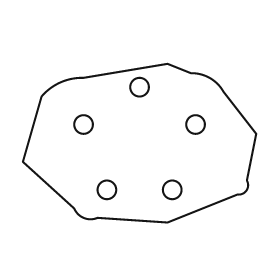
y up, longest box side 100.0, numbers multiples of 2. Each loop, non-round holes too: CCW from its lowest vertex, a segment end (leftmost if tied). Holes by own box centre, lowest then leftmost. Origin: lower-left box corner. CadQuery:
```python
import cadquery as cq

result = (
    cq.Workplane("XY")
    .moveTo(62.0, 0.0)
    .lineTo(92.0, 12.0)
    .threePointArc((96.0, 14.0), (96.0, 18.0))
    .lineTo(100.0, 38.0)
    .lineTo(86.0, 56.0)
    .threePointArc((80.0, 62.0), (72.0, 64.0))
    .lineTo(62.0, 68.0)
    .lineTo(26.0, 62.0)
    .threePointArc((16.0, 60.0), (8.0, 54.0))
    .lineTo(0.0, 26.0)
    .lineTo(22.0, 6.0)
    .threePointArc((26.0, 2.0), (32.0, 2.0))
    .close()
    .moveTo(36.0, 14.0)
    .circle(4.0)
    .moveTo(64.0, 14.0)
    .circle(4.0)
    .moveTo(26.0, 42.0)
    .circle(4.0)
    .moveTo(74.0, 42.0)
    .circle(4.0)
    .moveTo(50.0, 58.0)
    .circle(4.0)
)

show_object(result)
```